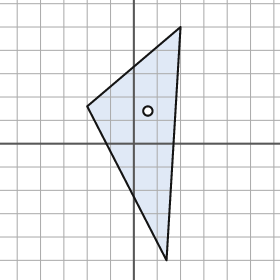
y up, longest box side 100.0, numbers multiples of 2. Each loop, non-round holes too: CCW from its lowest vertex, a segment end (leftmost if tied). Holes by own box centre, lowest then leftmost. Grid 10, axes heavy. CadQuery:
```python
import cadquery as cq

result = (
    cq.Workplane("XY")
    .moveTo(14.0, -50.0)
    .lineTo(20.0, 50.0)
    .lineTo(-20.0, 16.0)
    .close()
    .moveTo(6.0, 14.0)
    .circle(2.0)
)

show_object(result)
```